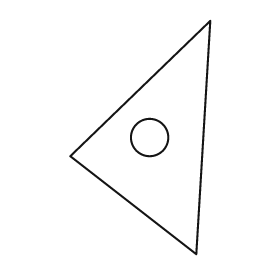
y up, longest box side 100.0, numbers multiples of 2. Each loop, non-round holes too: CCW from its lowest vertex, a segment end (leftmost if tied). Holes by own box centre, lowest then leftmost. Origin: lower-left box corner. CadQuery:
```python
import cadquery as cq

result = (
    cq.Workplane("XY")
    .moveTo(54.0, 0.0)
    .lineTo(60.0, 100.0)
    .lineTo(0.0, 42.0)
    .close()
    .moveTo(34.0, 50.0)
    .circle(8.0)
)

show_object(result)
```